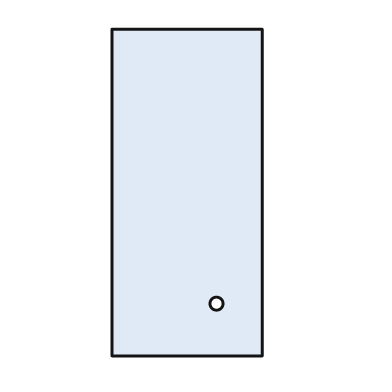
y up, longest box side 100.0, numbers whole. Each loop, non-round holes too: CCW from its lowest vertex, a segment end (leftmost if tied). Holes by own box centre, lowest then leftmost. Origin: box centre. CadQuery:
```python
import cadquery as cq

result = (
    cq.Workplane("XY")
    .moveTo(-23.0, -50.0)
    .lineTo(23.0, -50.0)
    .lineTo(23.0, 50.0)
    .lineTo(-23.0, 50.0)
    .close()
    .moveTo(9.0, -34.0)
    .circle(2.0)
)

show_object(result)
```